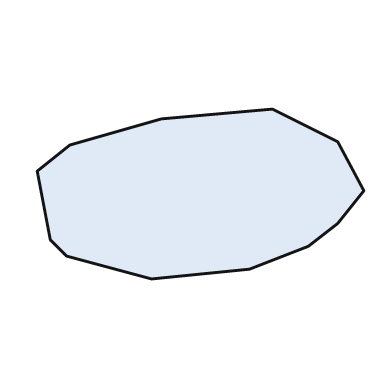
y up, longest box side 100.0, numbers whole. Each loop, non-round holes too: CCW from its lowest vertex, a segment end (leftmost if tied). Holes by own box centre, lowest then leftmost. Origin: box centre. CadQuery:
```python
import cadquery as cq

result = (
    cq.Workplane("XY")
    .moveTo(-15.0, -26.0)
    .lineTo(15.0, -23.0)
    .lineTo(33.0, -16.0)
    .lineTo(42.0, -9.0)
    .lineTo(50.0, 1.0)
    .lineTo(42.0, 16.0)
    .lineTo(22.0, 26.0)
    .lineTo(-12.0, 23.0)
    .lineTo(-40.0, 15.0)
    .lineTo(-50.0, 7.0)
    .lineTo(-46.0, -14.0)
    .lineTo(-41.0, -19.0)
    .close()
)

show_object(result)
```